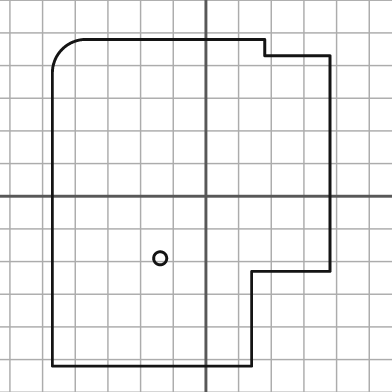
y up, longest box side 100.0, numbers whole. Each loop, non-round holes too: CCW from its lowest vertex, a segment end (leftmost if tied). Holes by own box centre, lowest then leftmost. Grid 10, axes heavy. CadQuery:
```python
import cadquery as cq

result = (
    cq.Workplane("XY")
    .moveTo(-47.0, -52.0)
    .lineTo(14.0, -52.0)
    .lineTo(14.0, -23.0)
    .lineTo(38.0, -23.0)
    .lineTo(38.0, 43.0)
    .lineTo(18.0, 43.0)
    .lineTo(18.0, 48.0)
    .lineTo(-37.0, 48.0)
    .threePointArc((-44.0, 45.0), (-47.0, 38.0))
    .close()
    .moveTo(-14.0, -19.0)
    .circle(2.0)
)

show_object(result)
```